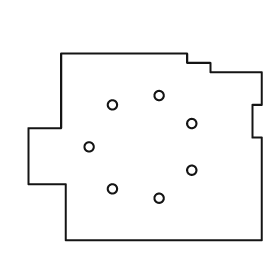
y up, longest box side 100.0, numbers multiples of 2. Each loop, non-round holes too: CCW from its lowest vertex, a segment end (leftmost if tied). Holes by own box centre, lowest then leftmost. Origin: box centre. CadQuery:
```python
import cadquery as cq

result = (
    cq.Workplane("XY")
    .moveTo(-34.0, -40.0)
    .lineTo(50.0, -40.0)
    .lineTo(50.0, 4.0)
    .lineTo(46.0, 4.0)
    .lineTo(46.0, 18.0)
    .lineTo(50.0, 18.0)
    .lineTo(50.0, 32.0)
    .lineTo(28.0, 32.0)
    .lineTo(28.0, 36.0)
    .lineTo(18.0, 36.0)
    .lineTo(18.0, 40.0)
    .lineTo(-36.0, 40.0)
    .lineTo(-36.0, 8.0)
    .lineTo(-50.0, 8.0)
    .lineTo(-50.0, -16.0)
    .lineTo(-34.0, -16.0)
    .close()
    .moveTo(6.0, -22.0)
    .circle(2.0)
    .moveTo(-14.0, -18.0)
    .circle(2.0)
    .moveTo(20.0, -10.0)
    .circle(2.0)
    .moveTo(-24.0, 0.0)
    .circle(2.0)
    .moveTo(20.0, 10.0)
    .circle(2.0)
    .moveTo(-14.0, 18.0)
    .circle(2.0)
    .moveTo(6.0, 22.0)
    .circle(2.0)
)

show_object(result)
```